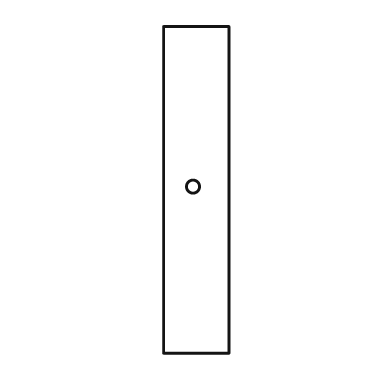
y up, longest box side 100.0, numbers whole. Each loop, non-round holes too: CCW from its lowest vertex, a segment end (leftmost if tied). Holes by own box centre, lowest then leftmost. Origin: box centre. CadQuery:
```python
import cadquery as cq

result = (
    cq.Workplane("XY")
    .moveTo(-10.0, -50.0)
    .lineTo(10.0, -50.0)
    .lineTo(10.0, 50.0)
    .lineTo(-10.0, 50.0)
    .close()
    .moveTo(-1.0, 1.0)
    .circle(2.0)
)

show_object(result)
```